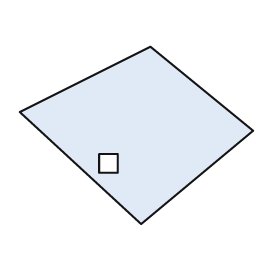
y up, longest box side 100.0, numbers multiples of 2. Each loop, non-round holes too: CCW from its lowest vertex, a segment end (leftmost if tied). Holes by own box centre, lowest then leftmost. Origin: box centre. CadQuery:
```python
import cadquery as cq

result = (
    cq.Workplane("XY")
    .moveTo(2.0, -38.0)
    .lineTo(50.0, 2.0)
    .lineTo(6.0, 38.0)
    .lineTo(-50.0, 10.0)
    .close()
    .moveTo(-16.0, -16.0)
    .lineTo(-8.0, -16.0)
    .lineTo(-8.0, -8.0)
    .lineTo(-16.0, -8.0)
    .close()
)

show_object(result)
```